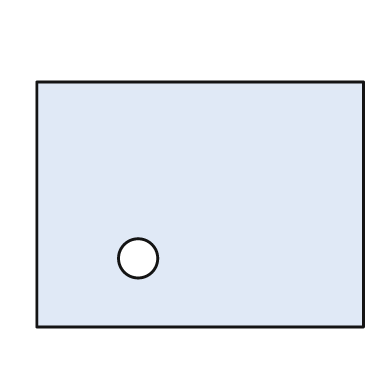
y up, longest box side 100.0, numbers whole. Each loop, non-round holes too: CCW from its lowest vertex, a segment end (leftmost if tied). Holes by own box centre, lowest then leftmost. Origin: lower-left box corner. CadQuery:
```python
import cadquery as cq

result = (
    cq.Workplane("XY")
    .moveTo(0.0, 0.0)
    .lineTo(100.0, 0.0)
    .lineTo(100.0, 75.0)
    .lineTo(0.0, 75.0)
    .close()
    .moveTo(31.0, 21.0)
    .circle(6.0)
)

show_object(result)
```